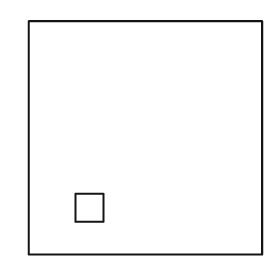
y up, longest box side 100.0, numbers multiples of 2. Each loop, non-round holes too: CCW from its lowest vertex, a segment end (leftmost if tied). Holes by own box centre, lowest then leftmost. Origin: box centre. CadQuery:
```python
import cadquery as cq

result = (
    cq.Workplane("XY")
    .moveTo(-50.0, -50.0)
    .lineTo(50.0, -50.0)
    .lineTo(50.0, 50.0)
    .lineTo(-50.0, 50.0)
    .close()
    .moveTo(-30.0, -36.0)
    .lineTo(-18.0, -36.0)
    .lineTo(-18.0, -24.0)
    .lineTo(-30.0, -24.0)
    .close()
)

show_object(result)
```